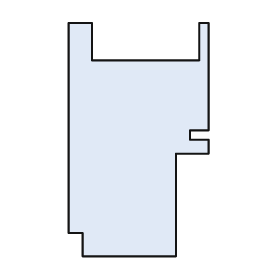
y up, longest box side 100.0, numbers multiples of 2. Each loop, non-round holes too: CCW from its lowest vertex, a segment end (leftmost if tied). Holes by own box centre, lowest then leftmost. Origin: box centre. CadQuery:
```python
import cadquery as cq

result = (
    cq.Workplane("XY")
    .moveTo(-24.0, -50.0)
    .lineTo(16.0, -50.0)
    .lineTo(16.0, -6.0)
    .lineTo(30.0, -6.0)
    .lineTo(30.0, 0.0)
    .lineTo(22.0, 0.0)
    .lineTo(22.0, 4.0)
    .lineTo(30.0, 4.0)
    .lineTo(30.0, 50.0)
    .lineTo(26.0, 50.0)
    .lineTo(26.0, 34.0)
    .lineTo(-20.0, 34.0)
    .lineTo(-20.0, 50.0)
    .lineTo(-30.0, 50.0)
    .lineTo(-30.0, -40.0)
    .lineTo(-24.0, -40.0)
    .close()
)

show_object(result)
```